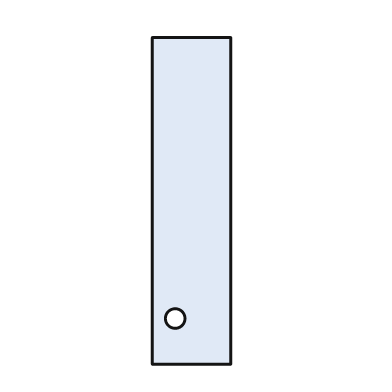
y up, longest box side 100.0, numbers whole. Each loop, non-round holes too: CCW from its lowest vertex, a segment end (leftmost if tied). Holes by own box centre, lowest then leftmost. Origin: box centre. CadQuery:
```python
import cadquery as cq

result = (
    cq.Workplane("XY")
    .moveTo(-12.0, -50.0)
    .lineTo(12.0, -50.0)
    .lineTo(12.0, 50.0)
    .lineTo(-12.0, 50.0)
    .close()
    .moveTo(-5.0, -36.0)
    .circle(3.0)
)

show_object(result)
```